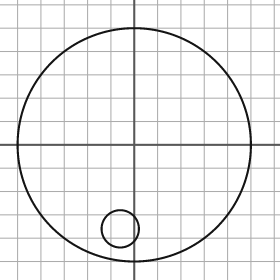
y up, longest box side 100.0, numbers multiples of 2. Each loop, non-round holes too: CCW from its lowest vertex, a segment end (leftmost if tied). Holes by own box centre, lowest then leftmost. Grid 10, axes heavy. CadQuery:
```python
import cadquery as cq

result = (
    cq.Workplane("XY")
    .moveTo(0.0, 0.0)
    .circle(50.0)
    .moveTo(-6.0, -36.0)
    .circle(8.0)
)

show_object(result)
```